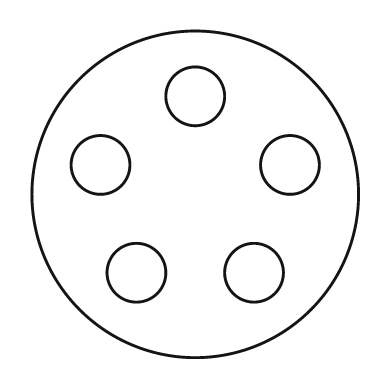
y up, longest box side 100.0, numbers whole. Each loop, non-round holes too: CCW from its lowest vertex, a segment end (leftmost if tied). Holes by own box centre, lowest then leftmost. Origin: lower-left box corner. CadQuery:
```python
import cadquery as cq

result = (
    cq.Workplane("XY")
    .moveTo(50.0, 50.0)
    .circle(50.0)
    .moveTo(32.0, 26.0)
    .circle(9.0)
    .moveTo(68.0, 26.0)
    .circle(9.0)
    .moveTo(21.0, 59.0)
    .circle(9.0)
    .moveTo(79.0, 59.0)
    .circle(9.0)
    .moveTo(50.0, 80.0)
    .circle(9.0)
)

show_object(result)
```